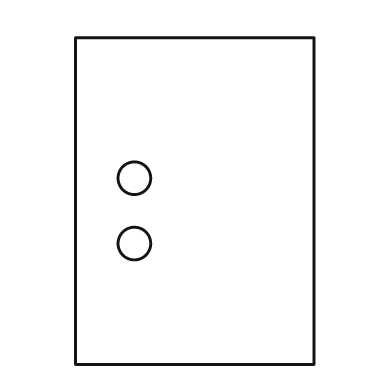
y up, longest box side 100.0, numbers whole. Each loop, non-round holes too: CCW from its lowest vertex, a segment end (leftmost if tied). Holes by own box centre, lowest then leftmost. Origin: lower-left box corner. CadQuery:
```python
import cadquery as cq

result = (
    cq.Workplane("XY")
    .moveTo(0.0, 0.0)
    .lineTo(73.0, 0.0)
    .lineTo(73.0, 100.0)
    .lineTo(0.0, 100.0)
    .close()
    .moveTo(18.0, 37.0)
    .circle(5.0)
    .moveTo(18.0, 57.0)
    .circle(5.0)
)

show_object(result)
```